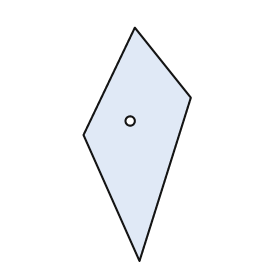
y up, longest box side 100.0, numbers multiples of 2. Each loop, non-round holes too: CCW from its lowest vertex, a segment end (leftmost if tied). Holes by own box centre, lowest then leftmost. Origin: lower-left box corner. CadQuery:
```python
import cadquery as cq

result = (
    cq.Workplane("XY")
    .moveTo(24.0, 0.0)
    .lineTo(46.0, 70.0)
    .lineTo(22.0, 100.0)
    .lineTo(0.0, 54.0)
    .close()
    .moveTo(20.0, 60.0)
    .circle(2.0)
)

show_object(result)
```